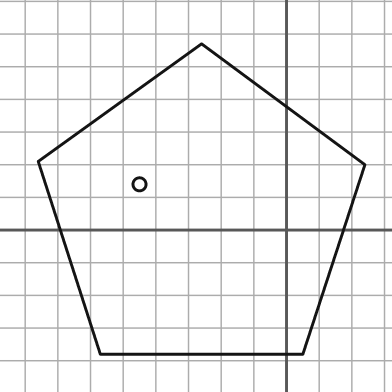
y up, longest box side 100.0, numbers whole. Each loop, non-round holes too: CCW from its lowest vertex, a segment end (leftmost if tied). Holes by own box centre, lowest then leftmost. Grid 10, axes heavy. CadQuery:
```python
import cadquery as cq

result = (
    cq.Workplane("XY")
    .moveTo(-57.0, -38.0)
    .lineTo(5.0, -38.0)
    .lineTo(24.0, 20.0)
    .lineTo(-26.0, 57.0)
    .lineTo(-76.0, 21.0)
    .close()
    .moveTo(-45.0, 14.0)
    .circle(2.0)
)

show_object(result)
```